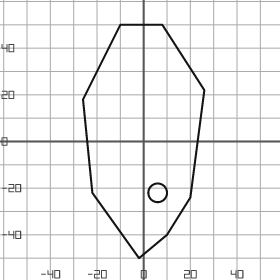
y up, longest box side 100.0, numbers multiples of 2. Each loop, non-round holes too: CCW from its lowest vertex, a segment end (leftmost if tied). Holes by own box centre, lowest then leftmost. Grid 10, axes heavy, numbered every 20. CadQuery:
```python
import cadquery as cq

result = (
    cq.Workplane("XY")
    .moveTo(-2.0, -50.0)
    .lineTo(10.0, -40.0)
    .lineTo(20.0, -24.0)
    .lineTo(26.0, 22.0)
    .lineTo(8.0, 50.0)
    .lineTo(-10.0, 50.0)
    .lineTo(-26.0, 18.0)
    .lineTo(-22.0, -22.0)
    .close()
    .moveTo(6.0, -22.0)
    .circle(4.0)
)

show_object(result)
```